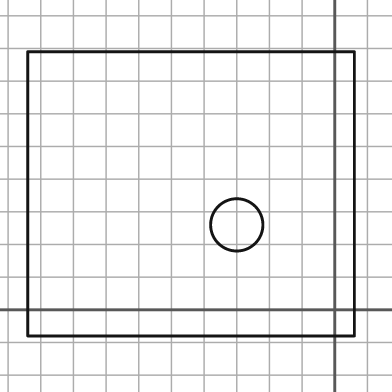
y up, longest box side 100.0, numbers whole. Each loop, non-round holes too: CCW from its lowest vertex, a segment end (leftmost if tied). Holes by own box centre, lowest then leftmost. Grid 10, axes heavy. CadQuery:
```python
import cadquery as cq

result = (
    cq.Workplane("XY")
    .moveTo(-94.0, -8.0)
    .lineTo(6.0, -8.0)
    .lineTo(6.0, 79.0)
    .lineTo(-94.0, 79.0)
    .close()
    .moveTo(-30.0, 26.0)
    .circle(8.0)
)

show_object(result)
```